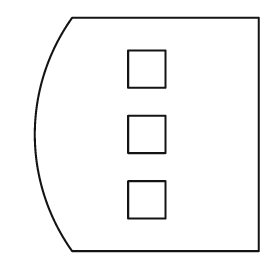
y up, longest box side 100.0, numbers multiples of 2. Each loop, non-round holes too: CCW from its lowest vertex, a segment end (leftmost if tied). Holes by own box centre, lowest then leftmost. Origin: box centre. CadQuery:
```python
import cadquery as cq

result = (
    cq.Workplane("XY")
    .moveTo(-32.0, -50.0)
    .lineTo(48.0, -50.0)
    .lineTo(48.0, 50.0)
    .lineTo(-32.0, 50.0)
    .threePointArc((-48.0, 0.0), (-32.0, -50.0))
    .close()
    .moveTo(-8.0, -36.0)
    .lineTo(8.0, -36.0)
    .lineTo(8.0, -20.0)
    .lineTo(-8.0, -20.0)
    .close()
    .moveTo(-8.0, -8.0)
    .lineTo(8.0, -8.0)
    .lineTo(8.0, 8.0)
    .lineTo(-8.0, 8.0)
    .close()
    .moveTo(-8.0, 20.0)
    .lineTo(8.0, 20.0)
    .lineTo(8.0, 36.0)
    .lineTo(-8.0, 36.0)
    .close()
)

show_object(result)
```